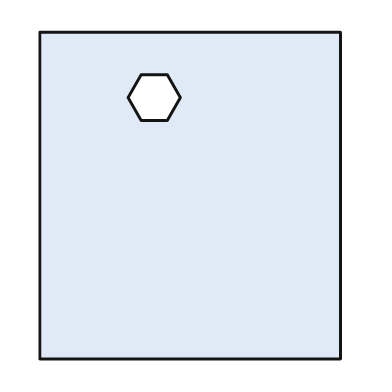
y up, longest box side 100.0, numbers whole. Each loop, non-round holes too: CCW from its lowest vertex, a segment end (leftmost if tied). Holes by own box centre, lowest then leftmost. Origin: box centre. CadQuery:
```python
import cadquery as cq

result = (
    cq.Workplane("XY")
    .moveTo(-46.0, -50.0)
    .lineTo(46.0, -50.0)
    .lineTo(46.0, 50.0)
    .lineTo(-46.0, 50.0)
    .close()
    .moveTo(-15.0, 23.0)
    .lineTo(-7.0, 23.0)
    .lineTo(-3.0, 30.0)
    .lineTo(-7.0, 37.0)
    .lineTo(-15.0, 37.0)
    .lineTo(-19.0, 30.0)
    .close()
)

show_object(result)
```